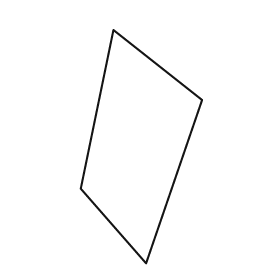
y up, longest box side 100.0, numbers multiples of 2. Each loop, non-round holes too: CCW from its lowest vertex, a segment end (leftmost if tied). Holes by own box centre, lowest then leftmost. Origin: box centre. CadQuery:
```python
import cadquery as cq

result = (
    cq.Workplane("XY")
    .moveTo(2.0, -50.0)
    .lineTo(26.0, 20.0)
    .lineTo(-12.0, 50.0)
    .lineTo(-26.0, -18.0)
    .close()
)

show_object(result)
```